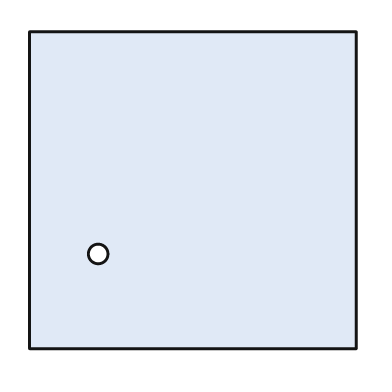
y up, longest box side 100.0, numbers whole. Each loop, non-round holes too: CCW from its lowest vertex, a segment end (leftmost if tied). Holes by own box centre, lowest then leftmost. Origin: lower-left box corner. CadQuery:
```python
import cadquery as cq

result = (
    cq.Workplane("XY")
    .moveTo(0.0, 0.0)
    .lineTo(100.0, 0.0)
    .lineTo(100.0, 97.0)
    .lineTo(0.0, 97.0)
    .close()
    .moveTo(21.0, 29.0)
    .circle(3.0)
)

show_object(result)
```